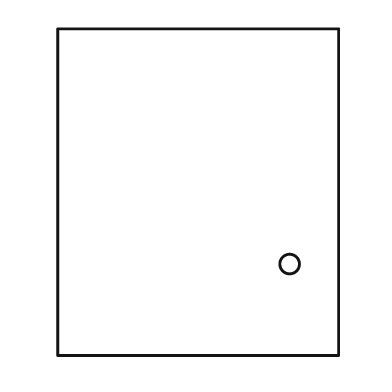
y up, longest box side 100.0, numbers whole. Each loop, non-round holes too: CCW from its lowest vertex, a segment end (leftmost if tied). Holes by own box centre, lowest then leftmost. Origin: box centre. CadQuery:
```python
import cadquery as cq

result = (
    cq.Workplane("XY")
    .moveTo(-43.0, -50.0)
    .lineTo(43.0, -50.0)
    .lineTo(43.0, 50.0)
    .lineTo(-43.0, 50.0)
    .close()
    .moveTo(28.0, -22.0)
    .circle(3.0)
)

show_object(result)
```